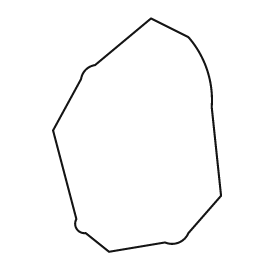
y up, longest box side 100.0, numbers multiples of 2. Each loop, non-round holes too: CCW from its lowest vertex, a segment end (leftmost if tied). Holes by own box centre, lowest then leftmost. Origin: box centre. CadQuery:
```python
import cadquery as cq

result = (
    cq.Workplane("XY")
    .moveTo(-12.0, -50.0)
    .lineTo(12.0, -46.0)
    .threePointArc((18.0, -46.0), (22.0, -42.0))
    .lineTo(36.0, -26.0)
    .lineTo(32.0, 12.0)
    .threePointArc((30.0, 28.0), (22.0, 42.0))
    .lineTo(6.0, 50.0)
    .lineTo(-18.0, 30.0)
    .threePointArc((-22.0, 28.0), (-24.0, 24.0))
    .lineTo(-36.0, 2.0)
    .lineTo(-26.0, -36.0)
    .threePointArc((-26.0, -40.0), (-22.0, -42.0))
    .close()
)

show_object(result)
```